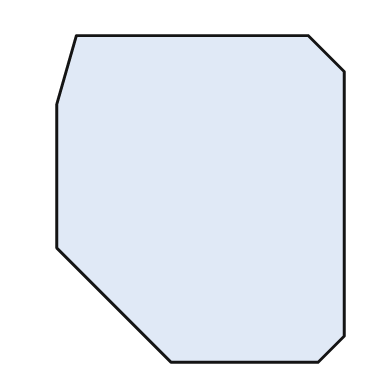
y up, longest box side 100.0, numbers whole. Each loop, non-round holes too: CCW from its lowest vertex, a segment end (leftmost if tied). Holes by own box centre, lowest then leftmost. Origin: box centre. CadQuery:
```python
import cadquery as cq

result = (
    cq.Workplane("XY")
    .moveTo(-9.0, -50.0)
    .lineTo(36.0, -50.0)
    .lineTo(44.0, -42.0)
    .lineTo(44.0, 39.0)
    .lineTo(33.0, 50.0)
    .lineTo(-38.0, 50.0)
    .lineTo(-44.0, 29.0)
    .lineTo(-44.0, -15.0)
    .close()
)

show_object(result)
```